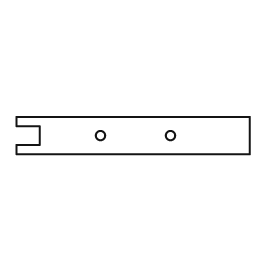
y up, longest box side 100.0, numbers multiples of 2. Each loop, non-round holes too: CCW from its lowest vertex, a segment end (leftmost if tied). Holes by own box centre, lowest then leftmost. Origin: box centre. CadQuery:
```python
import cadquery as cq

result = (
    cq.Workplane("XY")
    .moveTo(-50.0, -8.0)
    .lineTo(50.0, -8.0)
    .lineTo(50.0, 8.0)
    .lineTo(-50.0, 8.0)
    .lineTo(-50.0, 4.0)
    .lineTo(-40.0, 4.0)
    .lineTo(-40.0, -4.0)
    .lineTo(-50.0, -4.0)
    .close()
    .moveTo(-14.0, 0.0)
    .circle(2.0)
    .moveTo(16.0, 0.0)
    .circle(2.0)
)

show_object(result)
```